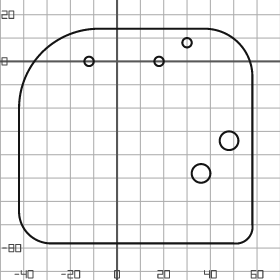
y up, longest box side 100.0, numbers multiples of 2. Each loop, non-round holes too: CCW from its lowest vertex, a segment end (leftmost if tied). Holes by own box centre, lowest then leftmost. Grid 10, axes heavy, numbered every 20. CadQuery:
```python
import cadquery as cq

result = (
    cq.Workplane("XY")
    .moveTo(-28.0, -78.0)
    .lineTo(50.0, -78.0)
    .threePointArc((56.0, -76.0), (58.0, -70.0))
    .lineTo(58.0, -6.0)
    .threePointArc((52.0, 8.0), (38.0, 14.0))
    .lineTo(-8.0, 14.0)
    .threePointArc((-32.0, 4.0), (-42.0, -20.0))
    .lineTo(-42.0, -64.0)
    .threePointArc((-38.0, -74.0), (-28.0, -78.0))
    .close()
    .moveTo(36.0, -48.0)
    .circle(4.0)
    .moveTo(48.0, -34.0)
    .circle(4.0)
    .moveTo(-12.0, 0.0)
    .circle(2.0)
    .moveTo(18.0, 0.0)
    .circle(2.0)
    .moveTo(30.0, 8.0)
    .circle(2.0)
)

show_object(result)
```